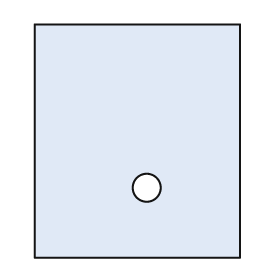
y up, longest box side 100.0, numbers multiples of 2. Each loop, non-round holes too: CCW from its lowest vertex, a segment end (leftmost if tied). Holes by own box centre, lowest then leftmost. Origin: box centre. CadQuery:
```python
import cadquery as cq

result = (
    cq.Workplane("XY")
    .moveTo(-44.0, -50.0)
    .lineTo(44.0, -50.0)
    .lineTo(44.0, 50.0)
    .lineTo(-44.0, 50.0)
    .close()
    .moveTo(4.0, -20.0)
    .circle(6.0)
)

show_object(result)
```